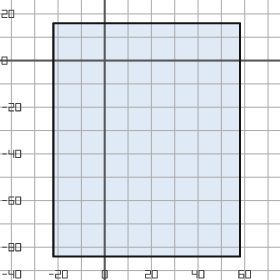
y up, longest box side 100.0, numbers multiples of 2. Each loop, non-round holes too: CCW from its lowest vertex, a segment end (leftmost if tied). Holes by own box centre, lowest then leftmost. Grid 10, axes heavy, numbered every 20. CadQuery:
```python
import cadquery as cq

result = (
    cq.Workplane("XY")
    .moveTo(-22.0, -84.0)
    .lineTo(58.0, -84.0)
    .lineTo(58.0, 16.0)
    .lineTo(-22.0, 16.0)
    .close()
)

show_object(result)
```